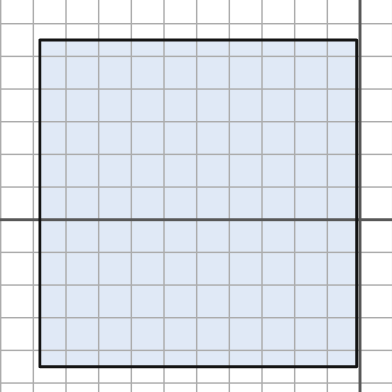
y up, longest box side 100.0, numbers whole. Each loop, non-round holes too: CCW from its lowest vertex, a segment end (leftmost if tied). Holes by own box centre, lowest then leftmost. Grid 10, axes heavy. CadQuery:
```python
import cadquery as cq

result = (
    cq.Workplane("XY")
    .moveTo(-98.0, -45.0)
    .lineTo(-1.0, -45.0)
    .lineTo(-1.0, 55.0)
    .lineTo(-98.0, 55.0)
    .close()
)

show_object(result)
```